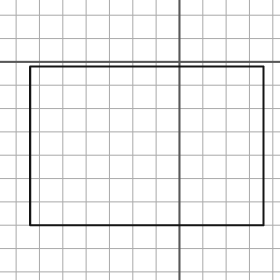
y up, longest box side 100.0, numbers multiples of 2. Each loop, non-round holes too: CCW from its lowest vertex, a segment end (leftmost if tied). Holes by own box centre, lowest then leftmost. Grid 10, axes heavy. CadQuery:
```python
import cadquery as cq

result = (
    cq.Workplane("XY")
    .moveTo(-64.0, -70.0)
    .lineTo(36.0, -70.0)
    .lineTo(36.0, -2.0)
    .lineTo(-64.0, -2.0)
    .close()
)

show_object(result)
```